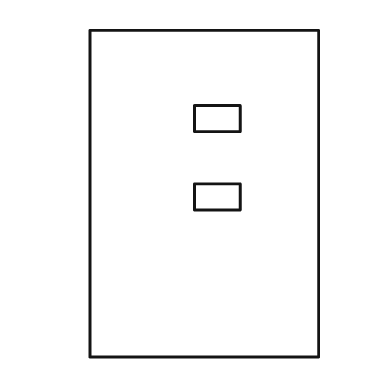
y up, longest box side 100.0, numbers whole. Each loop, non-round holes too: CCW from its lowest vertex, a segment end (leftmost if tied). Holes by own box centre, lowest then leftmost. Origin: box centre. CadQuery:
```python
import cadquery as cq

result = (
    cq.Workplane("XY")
    .moveTo(-35.0, -50.0)
    .lineTo(35.0, -50.0)
    .lineTo(35.0, 50.0)
    .lineTo(-35.0, 50.0)
    .close()
    .moveTo(-3.0, -5.0)
    .lineTo(11.0, -5.0)
    .lineTo(11.0, 3.0)
    .lineTo(-3.0, 3.0)
    .close()
    .moveTo(-3.0, 19.0)
    .lineTo(11.0, 19.0)
    .lineTo(11.0, 27.0)
    .lineTo(-3.0, 27.0)
    .close()
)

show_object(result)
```